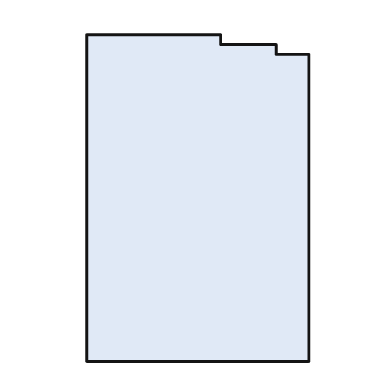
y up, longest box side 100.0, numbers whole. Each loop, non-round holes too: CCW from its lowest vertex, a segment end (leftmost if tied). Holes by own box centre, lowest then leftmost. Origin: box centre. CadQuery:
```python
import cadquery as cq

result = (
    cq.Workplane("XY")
    .moveTo(-34.0, -50.0)
    .lineTo(34.0, -50.0)
    .lineTo(34.0, 44.0)
    .lineTo(24.0, 44.0)
    .lineTo(24.0, 47.0)
    .lineTo(7.0, 47.0)
    .lineTo(7.0, 50.0)
    .lineTo(-34.0, 50.0)
    .close()
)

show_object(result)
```